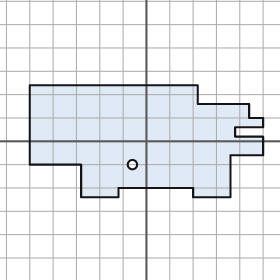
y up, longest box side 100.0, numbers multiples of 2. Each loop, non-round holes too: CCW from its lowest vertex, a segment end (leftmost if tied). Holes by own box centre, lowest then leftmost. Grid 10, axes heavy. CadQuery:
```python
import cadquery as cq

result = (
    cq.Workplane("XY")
    .moveTo(-28.0, -24.0)
    .lineTo(-12.0, -24.0)
    .lineTo(-12.0, -20.0)
    .lineTo(20.0, -20.0)
    .lineTo(20.0, -24.0)
    .lineTo(36.0, -24.0)
    .lineTo(36.0, -6.0)
    .lineTo(50.0, -6.0)
    .lineTo(50.0, 2.0)
    .lineTo(38.0, 2.0)
    .lineTo(38.0, 6.0)
    .lineTo(50.0, 6.0)
    .lineTo(50.0, 10.0)
    .lineTo(44.0, 10.0)
    .lineTo(44.0, 16.0)
    .lineTo(22.0, 16.0)
    .lineTo(22.0, 24.0)
    .lineTo(-50.0, 24.0)
    .lineTo(-50.0, -10.0)
    .lineTo(-28.0, -10.0)
    .close()
    .moveTo(-6.0, -10.0)
    .circle(2.0)
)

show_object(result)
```